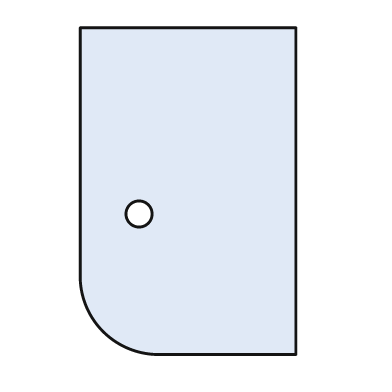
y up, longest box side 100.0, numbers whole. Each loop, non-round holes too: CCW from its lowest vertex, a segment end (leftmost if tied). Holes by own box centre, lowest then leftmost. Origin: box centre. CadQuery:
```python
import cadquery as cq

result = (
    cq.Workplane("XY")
    .moveTo(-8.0, -50.0)
    .lineTo(33.0, -50.0)
    .lineTo(33.0, 50.0)
    .lineTo(-33.0, 50.0)
    .lineTo(-33.0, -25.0)
    .threePointArc((-26.0, -43.0), (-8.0, -50.0))
    .close()
    .moveTo(-15.0, -7.0)
    .circle(4.0)
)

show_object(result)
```